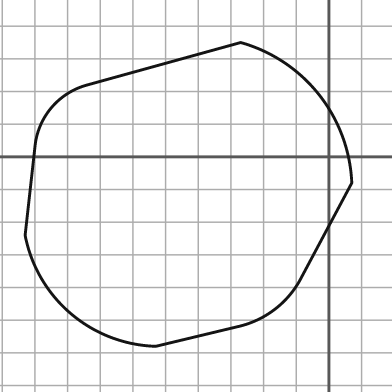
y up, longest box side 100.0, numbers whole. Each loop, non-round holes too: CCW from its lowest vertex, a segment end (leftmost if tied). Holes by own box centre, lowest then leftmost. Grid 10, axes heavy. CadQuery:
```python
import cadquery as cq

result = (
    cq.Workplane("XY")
    .moveTo(-53.0, -58.0)
    .lineTo(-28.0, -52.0)
    .threePointArc((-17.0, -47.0), (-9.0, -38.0))
    .lineTo(7.0, -8.0)
    .threePointArc((-3.0, 19.0), (-27.0, 35.0))
    .lineTo(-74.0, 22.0)
    .threePointArc((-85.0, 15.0), (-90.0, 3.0))
    .lineTo(-93.0, -24.0)
    .threePointArc((-79.0, -48.0), (-53.0, -58.0))
    .close()
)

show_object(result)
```